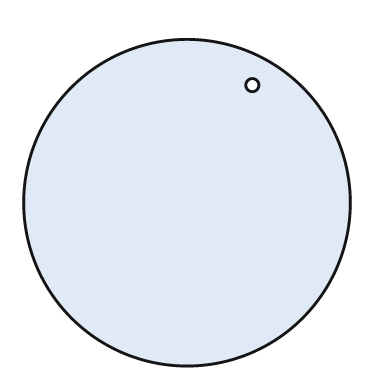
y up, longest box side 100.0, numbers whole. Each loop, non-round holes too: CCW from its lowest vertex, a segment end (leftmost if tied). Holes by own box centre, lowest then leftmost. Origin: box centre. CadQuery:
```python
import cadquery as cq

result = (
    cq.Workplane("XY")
    .moveTo(0.0, 0.0)
    .circle(50.0)
    .moveTo(20.0, 36.0)
    .circle(2.0)
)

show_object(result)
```